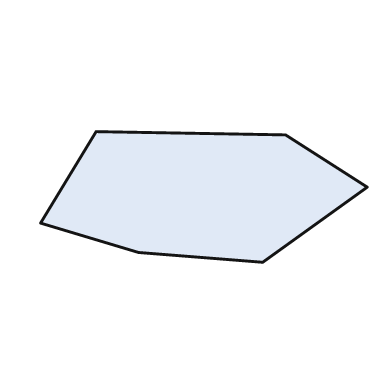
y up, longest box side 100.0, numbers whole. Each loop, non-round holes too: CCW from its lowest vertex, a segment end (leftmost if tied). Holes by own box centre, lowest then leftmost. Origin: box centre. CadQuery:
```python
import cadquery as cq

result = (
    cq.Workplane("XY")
    .moveTo(18.0, -20.0)
    .lineTo(50.0, 3.0)
    .lineTo(25.0, 19.0)
    .lineTo(-33.0, 20.0)
    .lineTo(-50.0, -8.0)
    .lineTo(-20.0, -17.0)
    .close()
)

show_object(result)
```